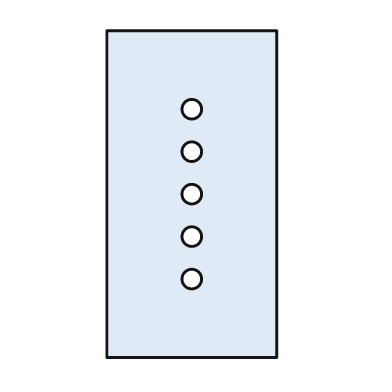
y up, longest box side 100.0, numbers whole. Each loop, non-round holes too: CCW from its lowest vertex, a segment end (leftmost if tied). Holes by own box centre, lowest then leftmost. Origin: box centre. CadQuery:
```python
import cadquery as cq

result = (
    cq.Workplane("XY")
    .moveTo(-26.0, -50.0)
    .lineTo(26.0, -50.0)
    .lineTo(26.0, 50.0)
    .lineTo(-26.0, 50.0)
    .close()
    .moveTo(0.0, -26.0)
    .circle(3.0)
    .moveTo(0.0, -13.0)
    .circle(3.0)
    .moveTo(0.0, 0.0)
    .circle(3.0)
    .moveTo(0.0, 13.0)
    .circle(3.0)
    .moveTo(0.0, 26.0)
    .circle(3.0)
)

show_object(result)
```